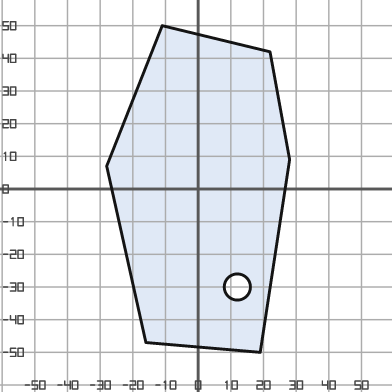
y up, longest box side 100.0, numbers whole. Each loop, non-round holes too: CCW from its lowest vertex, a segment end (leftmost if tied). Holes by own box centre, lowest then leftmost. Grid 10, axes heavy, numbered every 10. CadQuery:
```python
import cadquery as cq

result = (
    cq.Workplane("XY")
    .moveTo(19.0, -50.0)
    .lineTo(28.0, 9.0)
    .lineTo(22.0, 42.0)
    .lineTo(-11.0, 50.0)
    .lineTo(-28.0, 7.0)
    .lineTo(-16.0, -47.0)
    .close()
    .moveTo(12.0, -30.0)
    .circle(4.0)
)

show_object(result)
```